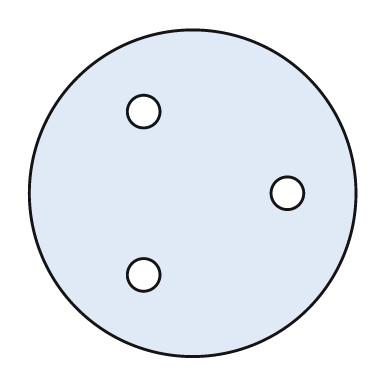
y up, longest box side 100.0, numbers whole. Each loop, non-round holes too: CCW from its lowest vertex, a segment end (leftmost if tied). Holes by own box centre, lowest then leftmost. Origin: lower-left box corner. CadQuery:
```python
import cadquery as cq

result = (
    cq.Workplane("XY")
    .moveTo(50.0, 50.0)
    .circle(50.0)
    .moveTo(35.0, 25.0)
    .circle(5.0)
    .moveTo(79.0, 50.0)
    .circle(5.0)
    .moveTo(35.0, 75.0)
    .circle(5.0)
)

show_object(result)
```